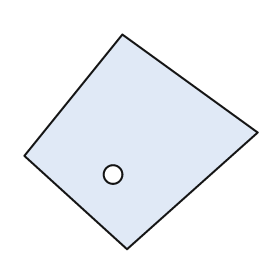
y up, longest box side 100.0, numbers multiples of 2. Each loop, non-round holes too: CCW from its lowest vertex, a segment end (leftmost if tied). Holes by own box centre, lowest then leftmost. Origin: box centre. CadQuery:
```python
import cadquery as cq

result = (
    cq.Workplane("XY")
    .moveTo(-6.0, -46.0)
    .lineTo(50.0, 4.0)
    .lineTo(-8.0, 46.0)
    .lineTo(-50.0, -6.0)
    .close()
    .moveTo(-12.0, -14.0)
    .circle(4.0)
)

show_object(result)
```